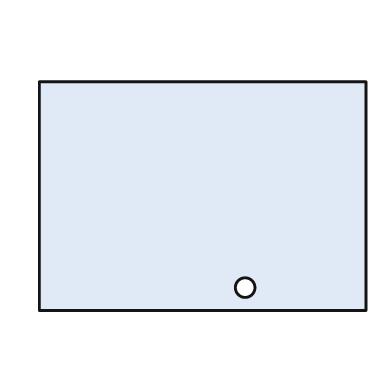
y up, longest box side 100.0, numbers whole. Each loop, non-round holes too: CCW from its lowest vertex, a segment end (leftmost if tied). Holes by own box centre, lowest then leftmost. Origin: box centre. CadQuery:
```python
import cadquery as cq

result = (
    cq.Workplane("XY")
    .moveTo(-50.0, -35.0)
    .lineTo(50.0, -35.0)
    .lineTo(50.0, 35.0)
    .lineTo(-50.0, 35.0)
    .close()
    .moveTo(13.0, -28.0)
    .circle(3.0)
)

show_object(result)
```